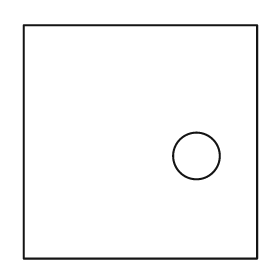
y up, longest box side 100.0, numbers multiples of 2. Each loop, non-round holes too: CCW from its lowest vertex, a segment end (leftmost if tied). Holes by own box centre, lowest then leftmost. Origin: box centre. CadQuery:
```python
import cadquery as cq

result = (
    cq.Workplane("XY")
    .moveTo(-50.0, -50.0)
    .lineTo(50.0, -50.0)
    .lineTo(50.0, 50.0)
    .lineTo(-50.0, 50.0)
    .close()
    .moveTo(24.0, -6.0)
    .circle(10.0)
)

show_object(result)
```